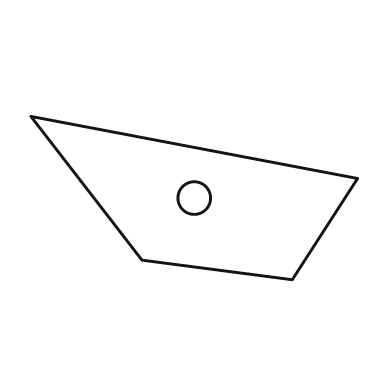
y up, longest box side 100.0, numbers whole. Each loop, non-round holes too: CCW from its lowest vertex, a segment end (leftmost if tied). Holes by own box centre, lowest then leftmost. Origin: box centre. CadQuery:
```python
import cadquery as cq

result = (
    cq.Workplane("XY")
    .moveTo(30.0, -25.0)
    .lineTo(50.0, 6.0)
    .lineTo(-50.0, 25.0)
    .lineTo(-16.0, -19.0)
    .close()
    .moveTo(0.0, 0.0)
    .circle(5.0)
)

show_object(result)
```